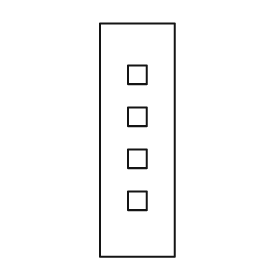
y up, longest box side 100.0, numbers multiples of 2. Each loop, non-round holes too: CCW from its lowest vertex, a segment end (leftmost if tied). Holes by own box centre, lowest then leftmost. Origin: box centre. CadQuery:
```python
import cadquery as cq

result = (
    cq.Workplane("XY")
    .moveTo(-16.0, -50.0)
    .lineTo(16.0, -50.0)
    .lineTo(16.0, 50.0)
    .lineTo(-16.0, 50.0)
    .close()
    .moveTo(-4.0, -30.0)
    .lineTo(4.0, -30.0)
    .lineTo(4.0, -22.0)
    .lineTo(-4.0, -22.0)
    .close()
    .moveTo(-4.0, -12.0)
    .lineTo(4.0, -12.0)
    .lineTo(4.0, -4.0)
    .lineTo(-4.0, -4.0)
    .close()
    .moveTo(-4.0, 6.0)
    .lineTo(4.0, 6.0)
    .lineTo(4.0, 14.0)
    .lineTo(-4.0, 14.0)
    .close()
    .moveTo(-4.0, 24.0)
    .lineTo(4.0, 24.0)
    .lineTo(4.0, 32.0)
    .lineTo(-4.0, 32.0)
    .close()
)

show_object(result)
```